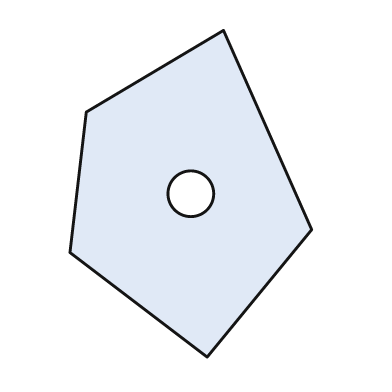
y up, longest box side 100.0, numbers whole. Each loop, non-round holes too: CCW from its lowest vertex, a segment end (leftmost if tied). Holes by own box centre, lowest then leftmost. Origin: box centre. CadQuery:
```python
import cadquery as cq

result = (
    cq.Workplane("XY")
    .moveTo(5.0, -50.0)
    .lineTo(37.0, -11.0)
    .lineTo(10.0, 50.0)
    .lineTo(-32.0, 25.0)
    .lineTo(-37.0, -18.0)
    .close()
    .moveTo(0.0, 0.0)
    .circle(7.0)
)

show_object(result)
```